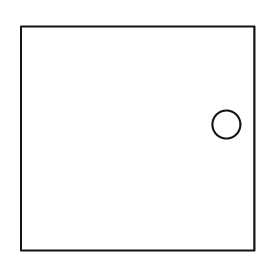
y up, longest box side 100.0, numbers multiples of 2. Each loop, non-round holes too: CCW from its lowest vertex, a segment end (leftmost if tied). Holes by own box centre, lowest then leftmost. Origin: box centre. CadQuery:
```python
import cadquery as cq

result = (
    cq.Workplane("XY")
    .moveTo(-50.0, -48.0)
    .lineTo(50.0, -48.0)
    .lineTo(50.0, 48.0)
    .lineTo(-50.0, 48.0)
    .close()
    .moveTo(38.0, 6.0)
    .circle(6.0)
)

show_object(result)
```